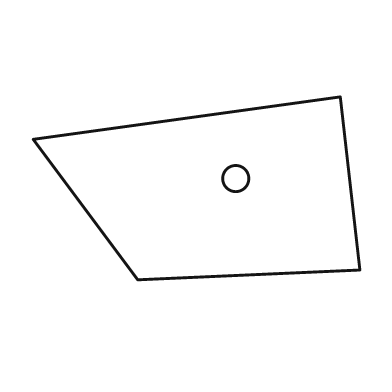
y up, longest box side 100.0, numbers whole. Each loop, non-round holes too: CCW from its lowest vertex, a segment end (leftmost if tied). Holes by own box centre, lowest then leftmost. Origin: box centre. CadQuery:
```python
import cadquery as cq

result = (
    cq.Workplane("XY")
    .moveTo(-18.0, -28.0)
    .lineTo(50.0, -25.0)
    .lineTo(44.0, 28.0)
    .lineTo(-50.0, 15.0)
    .close()
    .moveTo(12.0, 3.0)
    .circle(4.0)
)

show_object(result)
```